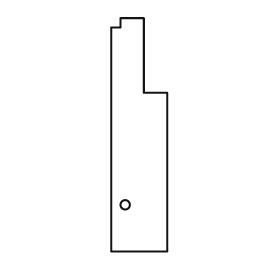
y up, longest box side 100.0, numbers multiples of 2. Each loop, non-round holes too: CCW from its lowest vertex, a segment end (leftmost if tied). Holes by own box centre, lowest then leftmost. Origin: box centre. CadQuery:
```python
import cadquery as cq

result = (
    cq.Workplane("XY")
    .moveTo(-12.0, -50.0)
    .lineTo(12.0, -50.0)
    .lineTo(12.0, 18.0)
    .lineTo(2.0, 18.0)
    .lineTo(2.0, 50.0)
    .lineTo(-8.0, 50.0)
    .lineTo(-8.0, 46.0)
    .lineTo(-12.0, 46.0)
    .close()
    .moveTo(-6.0, -30.0)
    .circle(2.0)
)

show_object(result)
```